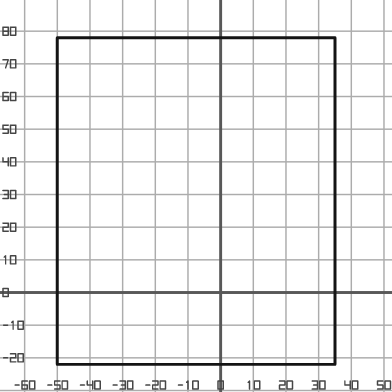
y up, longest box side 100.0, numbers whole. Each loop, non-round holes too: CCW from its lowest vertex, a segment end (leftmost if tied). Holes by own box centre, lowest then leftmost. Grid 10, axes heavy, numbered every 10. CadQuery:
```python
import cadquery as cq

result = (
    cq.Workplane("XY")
    .moveTo(-50.0, -22.0)
    .lineTo(35.0, -22.0)
    .lineTo(35.0, 78.0)
    .lineTo(-50.0, 78.0)
    .close()
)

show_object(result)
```